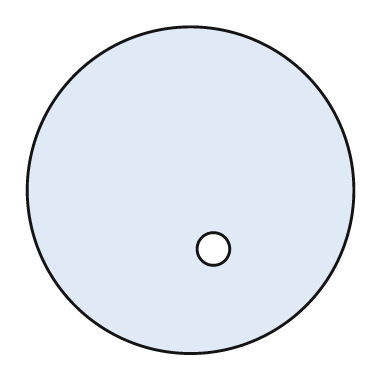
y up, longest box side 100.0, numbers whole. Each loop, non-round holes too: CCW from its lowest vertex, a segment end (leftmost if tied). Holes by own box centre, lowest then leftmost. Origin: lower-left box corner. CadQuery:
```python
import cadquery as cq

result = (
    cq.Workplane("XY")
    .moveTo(50.0, 50.0)
    .circle(50.0)
    .moveTo(57.0, 32.0)
    .circle(5.0)
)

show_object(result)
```